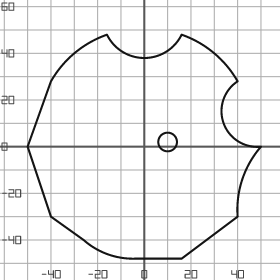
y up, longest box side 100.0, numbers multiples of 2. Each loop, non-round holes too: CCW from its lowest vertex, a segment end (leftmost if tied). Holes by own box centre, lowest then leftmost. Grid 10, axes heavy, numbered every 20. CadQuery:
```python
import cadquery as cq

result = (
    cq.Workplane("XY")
    .moveTo(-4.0, -48.0)
    .lineTo(16.0, -48.0)
    .lineTo(40.0, -30.0)
    .threePointArc((42.0, -14.0), (50.0, 0.0))
    .threePointArc((34.0, 10.0), (40.0, 28.0))
    .threePointArc((30.0, 40.0), (16.0, 48.0))
    .threePointArc((0.0, 38.0), (-16.0, 48.0))
    .threePointArc((-30.0, 40.0), (-40.0, 28.0))
    .lineTo(-50.0, 0.0)
    .lineTo(-40.0, -30.0)
    .lineTo(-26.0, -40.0)
    .threePointArc((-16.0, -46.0), (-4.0, -48.0))
    .close()
    .moveTo(10.0, 2.0)
    .circle(4.0)
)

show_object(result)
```